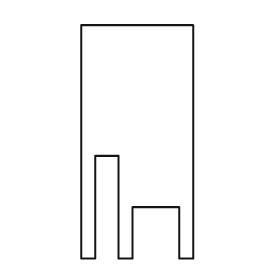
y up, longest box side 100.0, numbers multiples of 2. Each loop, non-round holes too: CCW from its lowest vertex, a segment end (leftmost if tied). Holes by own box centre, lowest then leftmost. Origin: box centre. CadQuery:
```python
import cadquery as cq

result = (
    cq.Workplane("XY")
    .moveTo(-24.0, -50.0)
    .lineTo(-18.0, -50.0)
    .lineTo(-18.0, -6.0)
    .lineTo(-8.0, -6.0)
    .lineTo(-8.0, -50.0)
    .lineTo(-2.0, -50.0)
    .lineTo(-2.0, -28.0)
    .lineTo(18.0, -28.0)
    .lineTo(18.0, -50.0)
    .lineTo(24.0, -50.0)
    .lineTo(24.0, 50.0)
    .lineTo(-24.0, 50.0)
    .close()
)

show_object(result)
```